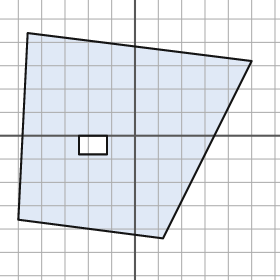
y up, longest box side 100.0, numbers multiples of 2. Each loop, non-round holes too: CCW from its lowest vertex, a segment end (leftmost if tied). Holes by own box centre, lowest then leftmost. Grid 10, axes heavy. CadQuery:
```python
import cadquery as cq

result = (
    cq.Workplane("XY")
    .moveTo(12.0, -44.0)
    .lineTo(50.0, 32.0)
    .lineTo(-46.0, 44.0)
    .lineTo(-50.0, -36.0)
    .close()
    .moveTo(-24.0, -8.0)
    .lineTo(-12.0, -8.0)
    .lineTo(-12.0, 0.0)
    .lineTo(-24.0, 0.0)
    .close()
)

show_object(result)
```